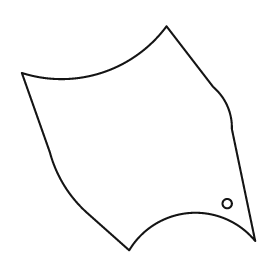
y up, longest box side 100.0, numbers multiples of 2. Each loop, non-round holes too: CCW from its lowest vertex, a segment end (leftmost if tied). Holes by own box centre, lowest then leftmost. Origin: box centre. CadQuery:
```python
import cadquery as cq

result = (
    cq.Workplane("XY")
    .moveTo(-4.0, -48.0)
    .threePointArc((22.0, -32.0), (50.0, -44.0))
    .lineTo(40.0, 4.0)
    .threePointArc((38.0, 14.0), (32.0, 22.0))
    .lineTo(12.0, 48.0)
    .threePointArc((-16.0, 28.0), (-50.0, 28.0))
    .lineTo(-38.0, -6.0)
    .threePointArc((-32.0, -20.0), (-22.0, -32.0))
    .close()
    .moveTo(38.0, -28.0)
    .circle(2.0)
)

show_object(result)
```